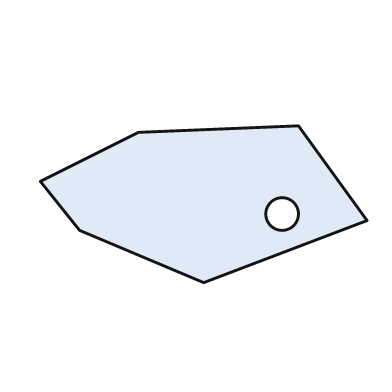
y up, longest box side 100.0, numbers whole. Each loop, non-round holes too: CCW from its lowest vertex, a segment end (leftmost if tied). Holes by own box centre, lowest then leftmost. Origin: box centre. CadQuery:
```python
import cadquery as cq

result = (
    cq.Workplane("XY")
    .moveTo(0.0, -24.0)
    .lineTo(50.0, -5.0)
    .lineTo(29.0, 24.0)
    .lineTo(-20.0, 22.0)
    .lineTo(-50.0, 7.0)
    .lineTo(-38.0, -8.0)
    .close()
    .moveTo(24.0, -3.0)
    .circle(5.0)
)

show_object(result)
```